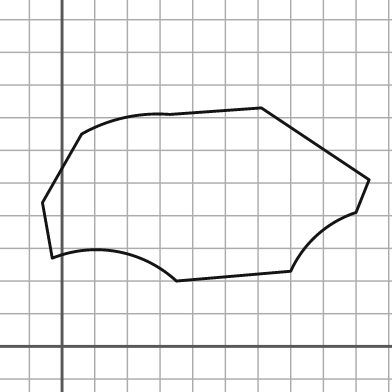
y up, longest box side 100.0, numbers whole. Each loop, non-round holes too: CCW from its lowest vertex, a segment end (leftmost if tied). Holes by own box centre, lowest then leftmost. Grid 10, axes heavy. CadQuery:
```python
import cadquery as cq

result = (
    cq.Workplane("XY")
    .moveTo(35.0, 20.0)
    .lineTo(70.0, 23.0)
    .threePointArc((78.0, 34.0), (90.0, 41.0))
    .lineTo(94.0, 51.0)
    .lineTo(61.0, 73.0)
    .lineTo(33.0, 71.0)
    .threePointArc((19.0, 70.0), (6.0, 65.0))
    .lineTo(-6.0, 44.0)
    .lineTo(-3.0, 27.0)
    .threePointArc((17.0, 29.0), (35.0, 20.0))
    .close()
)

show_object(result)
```